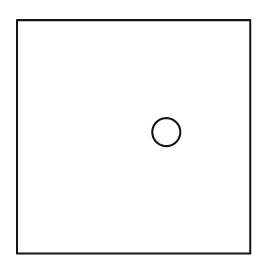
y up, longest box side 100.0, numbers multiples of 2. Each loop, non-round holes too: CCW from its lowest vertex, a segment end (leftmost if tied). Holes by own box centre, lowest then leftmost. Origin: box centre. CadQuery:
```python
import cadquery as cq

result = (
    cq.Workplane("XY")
    .moveTo(-50.0, -50.0)
    .lineTo(50.0, -50.0)
    .lineTo(50.0, 50.0)
    .lineTo(-50.0, 50.0)
    .close()
    .moveTo(14.0, 2.0)
    .circle(6.0)
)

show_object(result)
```